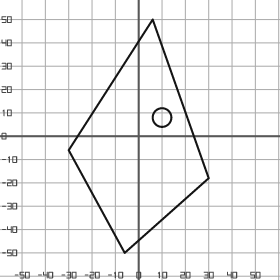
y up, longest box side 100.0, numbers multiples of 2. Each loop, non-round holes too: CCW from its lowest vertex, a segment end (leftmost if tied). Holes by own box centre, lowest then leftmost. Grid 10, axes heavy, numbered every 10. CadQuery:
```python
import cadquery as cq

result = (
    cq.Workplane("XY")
    .moveTo(-6.0, -50.0)
    .lineTo(30.0, -18.0)
    .lineTo(6.0, 50.0)
    .lineTo(-30.0, -6.0)
    .close()
    .moveTo(10.0, 8.0)
    .circle(4.0)
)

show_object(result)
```